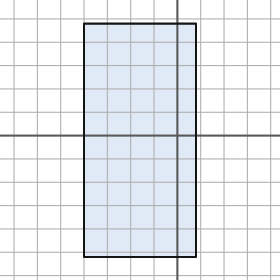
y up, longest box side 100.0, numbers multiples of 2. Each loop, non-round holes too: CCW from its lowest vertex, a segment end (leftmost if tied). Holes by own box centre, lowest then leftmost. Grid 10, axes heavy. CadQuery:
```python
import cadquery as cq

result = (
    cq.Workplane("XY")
    .moveTo(-40.0, -52.0)
    .lineTo(8.0, -52.0)
    .lineTo(8.0, 48.0)
    .lineTo(-40.0, 48.0)
    .close()
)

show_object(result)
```